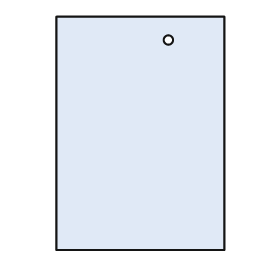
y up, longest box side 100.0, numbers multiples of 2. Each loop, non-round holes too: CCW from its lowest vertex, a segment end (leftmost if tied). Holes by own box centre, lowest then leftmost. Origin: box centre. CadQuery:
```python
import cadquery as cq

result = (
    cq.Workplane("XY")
    .moveTo(-36.0, -50.0)
    .lineTo(36.0, -50.0)
    .lineTo(36.0, 50.0)
    .lineTo(-36.0, 50.0)
    .close()
    .moveTo(12.0, 40.0)
    .circle(2.0)
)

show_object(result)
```